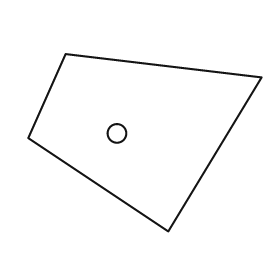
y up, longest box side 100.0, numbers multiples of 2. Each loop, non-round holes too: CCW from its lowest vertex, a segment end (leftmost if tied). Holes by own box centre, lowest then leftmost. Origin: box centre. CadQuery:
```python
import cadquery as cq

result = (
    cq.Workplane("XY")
    .moveTo(10.0, -38.0)
    .lineTo(50.0, 28.0)
    .lineTo(-34.0, 38.0)
    .lineTo(-50.0, 2.0)
    .close()
    .moveTo(-12.0, 4.0)
    .circle(4.0)
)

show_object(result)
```